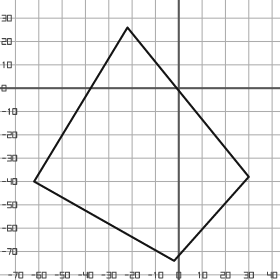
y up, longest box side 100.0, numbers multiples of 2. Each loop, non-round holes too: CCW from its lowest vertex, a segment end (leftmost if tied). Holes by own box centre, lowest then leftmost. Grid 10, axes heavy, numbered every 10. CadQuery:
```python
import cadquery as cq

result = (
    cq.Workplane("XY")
    .moveTo(-2.0, -74.0)
    .lineTo(30.0, -38.0)
    .lineTo(-22.0, 26.0)
    .lineTo(-62.0, -40.0)
    .close()
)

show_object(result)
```